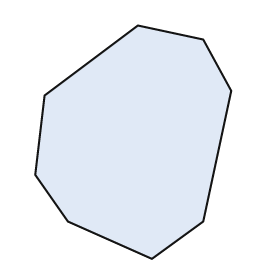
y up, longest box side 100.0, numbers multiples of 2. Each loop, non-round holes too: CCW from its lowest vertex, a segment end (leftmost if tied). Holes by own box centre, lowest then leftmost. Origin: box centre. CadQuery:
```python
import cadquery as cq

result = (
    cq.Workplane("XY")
    .moveTo(8.0, -50.0)
    .lineTo(30.0, -34.0)
    .lineTo(42.0, 22.0)
    .lineTo(30.0, 44.0)
    .lineTo(2.0, 50.0)
    .lineTo(-38.0, 20.0)
    .lineTo(-42.0, -14.0)
    .lineTo(-28.0, -34.0)
    .close()
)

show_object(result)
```